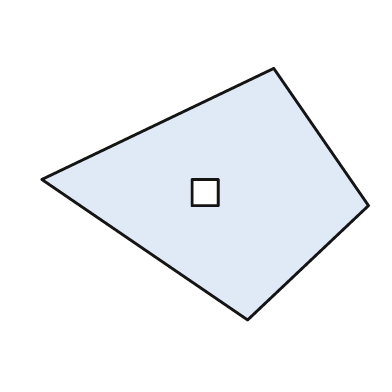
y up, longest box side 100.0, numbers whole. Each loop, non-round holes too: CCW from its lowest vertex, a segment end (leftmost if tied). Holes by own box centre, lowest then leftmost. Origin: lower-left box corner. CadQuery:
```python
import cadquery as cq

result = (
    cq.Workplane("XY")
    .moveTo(63.0, 0.0)
    .lineTo(100.0, 35.0)
    .lineTo(71.0, 77.0)
    .lineTo(0.0, 43.0)
    .close()
    .moveTo(46.0, 35.0)
    .lineTo(54.0, 35.0)
    .lineTo(54.0, 43.0)
    .lineTo(46.0, 43.0)
    .close()
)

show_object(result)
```